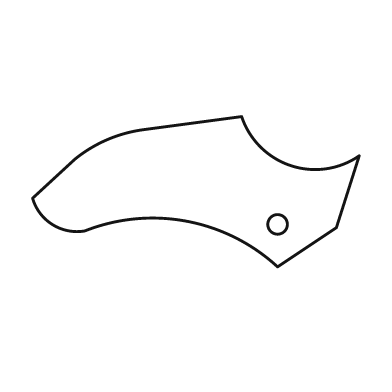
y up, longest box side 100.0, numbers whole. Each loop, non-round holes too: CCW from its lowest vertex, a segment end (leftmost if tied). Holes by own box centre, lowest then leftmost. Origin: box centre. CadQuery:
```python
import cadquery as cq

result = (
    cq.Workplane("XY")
    .moveTo(25.0, -23.0)
    .lineTo(43.0, -11.0)
    .lineTo(50.0, 11.0)
    .threePointArc((29.0, 8.0), (14.0, 23.0))
    .lineTo(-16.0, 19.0)
    .threePointArc((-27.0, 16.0), (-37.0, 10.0))
    .lineTo(-50.0, -2.0)
    .threePointArc((-44.0, -10.0), (-34.0, -12.0))
    .threePointArc((-3.0, -9.0), (25.0, -23.0))
    .close()
    .moveTo(25.0, -10.0)
    .circle(3.0)
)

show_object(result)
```